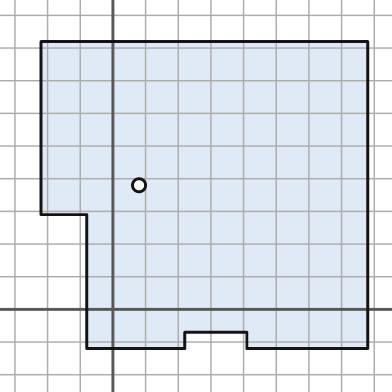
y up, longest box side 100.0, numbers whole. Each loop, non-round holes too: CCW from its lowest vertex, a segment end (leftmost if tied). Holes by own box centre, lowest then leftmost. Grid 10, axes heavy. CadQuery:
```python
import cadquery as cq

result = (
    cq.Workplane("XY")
    .moveTo(-8.0, -12.0)
    .lineTo(22.0, -12.0)
    .lineTo(22.0, -7.0)
    .lineTo(41.0, -7.0)
    .lineTo(41.0, -12.0)
    .lineTo(78.0, -12.0)
    .lineTo(78.0, 82.0)
    .lineTo(-22.0, 82.0)
    .lineTo(-22.0, 29.0)
    .lineTo(-8.0, 29.0)
    .close()
    .moveTo(8.0, 38.0)
    .circle(2.0)
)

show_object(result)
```